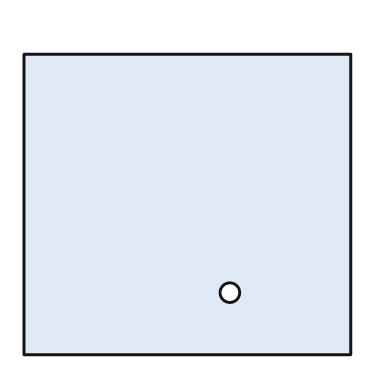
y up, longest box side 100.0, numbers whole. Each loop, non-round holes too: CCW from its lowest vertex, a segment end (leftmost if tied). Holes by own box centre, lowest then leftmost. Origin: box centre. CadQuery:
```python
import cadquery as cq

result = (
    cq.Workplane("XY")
    .moveTo(-50.0, -46.0)
    .lineTo(50.0, -46.0)
    .lineTo(50.0, 46.0)
    .lineTo(-50.0, 46.0)
    .close()
    .moveTo(13.0, -27.0)
    .circle(3.0)
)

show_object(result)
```